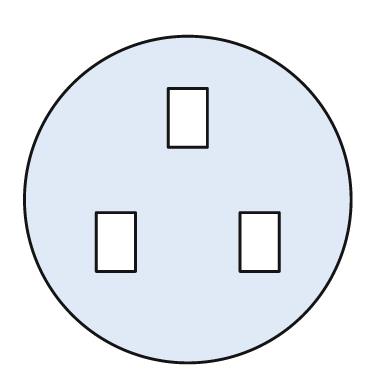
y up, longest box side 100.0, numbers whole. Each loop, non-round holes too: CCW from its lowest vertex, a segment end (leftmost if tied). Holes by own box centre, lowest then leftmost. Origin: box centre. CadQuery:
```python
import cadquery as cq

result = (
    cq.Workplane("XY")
    .moveTo(0.0, 0.0)
    .circle(50.0)
    .moveTo(-28.0, -22.0)
    .lineTo(-16.0, -22.0)
    .lineTo(-16.0, -4.0)
    .lineTo(-28.0, -4.0)
    .close()
    .moveTo(16.0, -22.0)
    .lineTo(28.0, -22.0)
    .lineTo(28.0, -4.0)
    .lineTo(16.0, -4.0)
    .close()
    .moveTo(-6.0, 16.0)
    .lineTo(6.0, 16.0)
    .lineTo(6.0, 34.0)
    .lineTo(-6.0, 34.0)
    .close()
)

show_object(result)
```